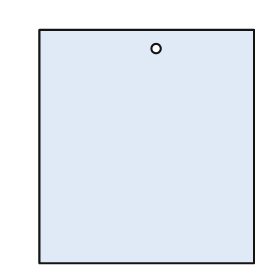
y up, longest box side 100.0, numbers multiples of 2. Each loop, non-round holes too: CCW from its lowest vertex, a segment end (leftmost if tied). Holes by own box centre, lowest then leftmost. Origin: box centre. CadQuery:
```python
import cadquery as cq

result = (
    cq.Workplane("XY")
    .moveTo(-46.0, -50.0)
    .lineTo(46.0, -50.0)
    .lineTo(46.0, 50.0)
    .lineTo(-46.0, 50.0)
    .close()
    .moveTo(4.0, 42.0)
    .circle(2.0)
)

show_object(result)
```